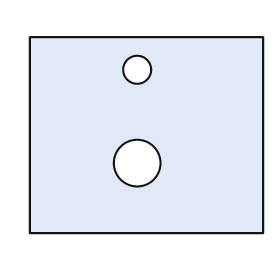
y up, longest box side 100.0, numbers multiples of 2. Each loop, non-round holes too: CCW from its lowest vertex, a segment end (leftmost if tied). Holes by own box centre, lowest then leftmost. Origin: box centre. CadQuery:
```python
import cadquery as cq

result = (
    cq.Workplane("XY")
    .moveTo(-50.0, -42.0)
    .lineTo(50.0, -42.0)
    .lineTo(50.0, 42.0)
    .lineTo(-50.0, 42.0)
    .close()
    .moveTo(-4.0, -12.0)
    .circle(10.0)
    .moveTo(-4.0, 28.0)
    .circle(6.0)
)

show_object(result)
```